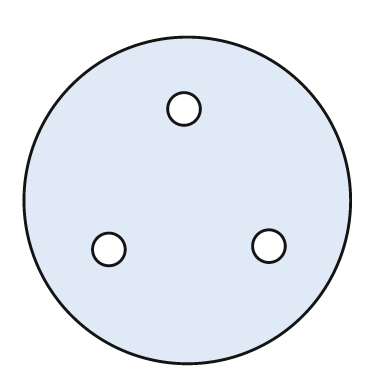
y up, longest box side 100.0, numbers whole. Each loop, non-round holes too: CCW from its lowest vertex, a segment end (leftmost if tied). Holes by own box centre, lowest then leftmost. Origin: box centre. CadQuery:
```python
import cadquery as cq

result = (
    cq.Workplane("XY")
    .moveTo(0.0, 0.0)
    .circle(50.0)
    .moveTo(-24.0, -15.0)
    .circle(5.0)
    .moveTo(25.0, -14.0)
    .circle(5.0)
    .moveTo(-1.0, 28.0)
    .circle(5.0)
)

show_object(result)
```